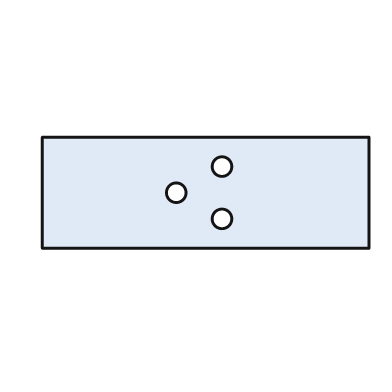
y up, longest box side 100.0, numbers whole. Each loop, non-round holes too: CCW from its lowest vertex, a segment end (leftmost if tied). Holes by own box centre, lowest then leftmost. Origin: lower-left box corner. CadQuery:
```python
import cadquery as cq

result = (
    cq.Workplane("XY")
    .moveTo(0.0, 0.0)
    .lineTo(100.0, 0.0)
    .lineTo(100.0, 34.0)
    .lineTo(0.0, 34.0)
    .close()
    .moveTo(55.0, 9.0)
    .circle(3.0)
    .moveTo(41.0, 17.0)
    .circle(3.0)
    .moveTo(55.0, 25.0)
    .circle(3.0)
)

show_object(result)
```